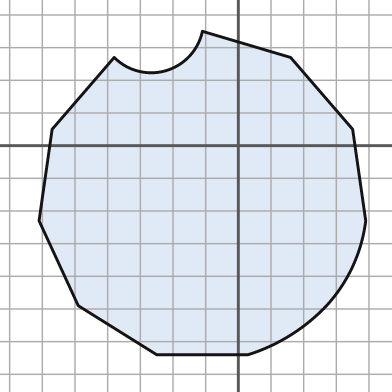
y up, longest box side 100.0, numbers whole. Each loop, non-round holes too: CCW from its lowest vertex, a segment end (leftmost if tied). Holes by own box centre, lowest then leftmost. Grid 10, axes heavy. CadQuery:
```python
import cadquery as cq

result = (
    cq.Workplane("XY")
    .moveTo(-25.0, -64.0)
    .lineTo(3.0, -64.0)
    .threePointArc((16.0, -58.0), (27.0, -49.0))
    .threePointArc((35.0, -37.0), (39.0, -23.0))
    .lineTo(35.0, 5.0)
    .lineTo(16.0, 27.0)
    .lineTo(-11.0, 35.0)
    .threePointArc((-22.0, 23.0), (-38.0, 27.0))
    .lineTo(-57.0, 5.0)
    .lineTo(-61.0, -23.0)
    .lineTo(-49.0, -49.0)
    .close()
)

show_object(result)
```